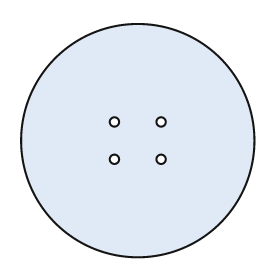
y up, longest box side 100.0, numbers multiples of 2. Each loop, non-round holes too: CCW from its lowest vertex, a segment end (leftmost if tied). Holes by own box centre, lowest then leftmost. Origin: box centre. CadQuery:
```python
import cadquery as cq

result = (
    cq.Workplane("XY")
    .moveTo(0.0, 0.0)
    .circle(50.0)
    .moveTo(-10.0, -8.0)
    .circle(2.0)
    .moveTo(10.0, -8.0)
    .circle(2.0)
    .moveTo(-10.0, 8.0)
    .circle(2.0)
    .moveTo(10.0, 8.0)
    .circle(2.0)
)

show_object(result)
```